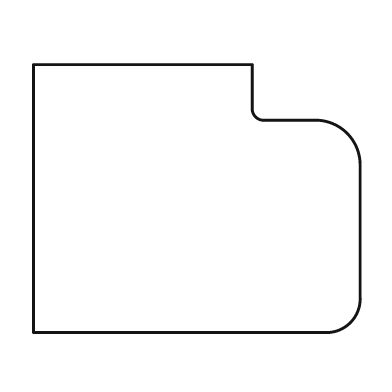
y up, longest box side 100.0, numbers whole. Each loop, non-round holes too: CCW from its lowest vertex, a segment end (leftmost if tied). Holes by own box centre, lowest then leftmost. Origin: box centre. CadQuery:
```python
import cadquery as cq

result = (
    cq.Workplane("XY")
    .moveTo(-50.0, -41.0)
    .lineTo(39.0, -41.0)
    .threePointArc((47.0, -38.0), (50.0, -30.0))
    .lineTo(50.0, 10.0)
    .threePointArc((46.0, 20.0), (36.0, 24.0))
    .lineTo(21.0, 24.0)
    .threePointArc((18.0, 25.0), (17.0, 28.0))
    .lineTo(17.0, 41.0)
    .lineTo(-50.0, 41.0)
    .close()
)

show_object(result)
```